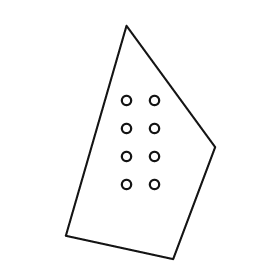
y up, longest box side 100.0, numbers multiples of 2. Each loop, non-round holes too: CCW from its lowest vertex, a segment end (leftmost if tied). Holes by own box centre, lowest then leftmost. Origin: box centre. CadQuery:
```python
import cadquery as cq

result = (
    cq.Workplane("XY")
    .moveTo(14.0, -50.0)
    .lineTo(32.0, -2.0)
    .lineTo(-6.0, 50.0)
    .lineTo(-32.0, -40.0)
    .close()
    .moveTo(-6.0, -18.0)
    .circle(2.0)
    .moveTo(6.0, -18.0)
    .circle(2.0)
    .moveTo(-6.0, -6.0)
    .circle(2.0)
    .moveTo(6.0, -6.0)
    .circle(2.0)
    .moveTo(-6.0, 6.0)
    .circle(2.0)
    .moveTo(6.0, 6.0)
    .circle(2.0)
    .moveTo(-6.0, 18.0)
    .circle(2.0)
    .moveTo(6.0, 18.0)
    .circle(2.0)
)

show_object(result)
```